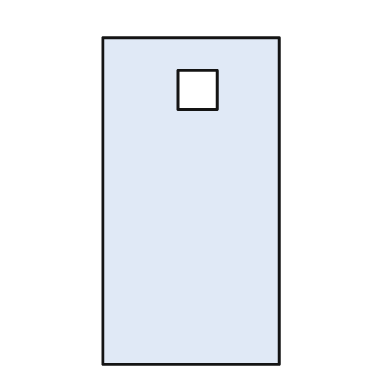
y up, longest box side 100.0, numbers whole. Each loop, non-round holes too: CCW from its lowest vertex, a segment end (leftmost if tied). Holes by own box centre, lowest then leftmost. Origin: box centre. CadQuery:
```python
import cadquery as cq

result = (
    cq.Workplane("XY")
    .moveTo(-27.0, -50.0)
    .lineTo(27.0, -50.0)
    .lineTo(27.0, 50.0)
    .lineTo(-27.0, 50.0)
    .close()
    .moveTo(-4.0, 28.0)
    .lineTo(8.0, 28.0)
    .lineTo(8.0, 40.0)
    .lineTo(-4.0, 40.0)
    .close()
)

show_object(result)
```